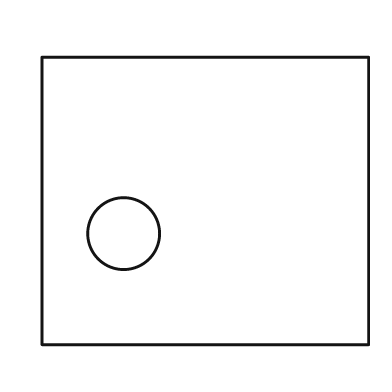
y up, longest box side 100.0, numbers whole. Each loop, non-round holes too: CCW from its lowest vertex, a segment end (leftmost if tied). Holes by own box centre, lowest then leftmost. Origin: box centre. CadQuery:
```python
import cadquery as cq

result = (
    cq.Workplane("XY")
    .moveTo(-50.0, -44.0)
    .lineTo(50.0, -44.0)
    .lineTo(50.0, 44.0)
    .lineTo(-50.0, 44.0)
    .close()
    .moveTo(-25.0, -10.0)
    .circle(11.0)
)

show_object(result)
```